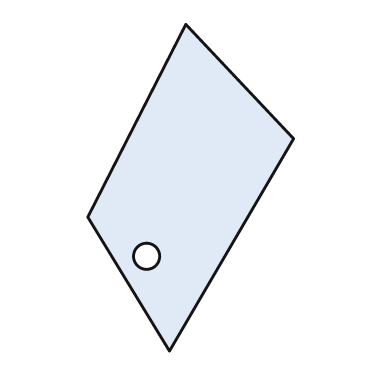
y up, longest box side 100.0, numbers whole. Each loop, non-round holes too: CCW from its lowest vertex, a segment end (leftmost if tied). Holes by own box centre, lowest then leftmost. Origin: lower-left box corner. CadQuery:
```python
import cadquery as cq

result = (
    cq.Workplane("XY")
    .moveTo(25.0, 0.0)
    .lineTo(63.0, 65.0)
    .lineTo(30.0, 100.0)
    .lineTo(0.0, 41.0)
    .close()
    .moveTo(18.0, 29.0)
    .circle(4.0)
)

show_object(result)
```